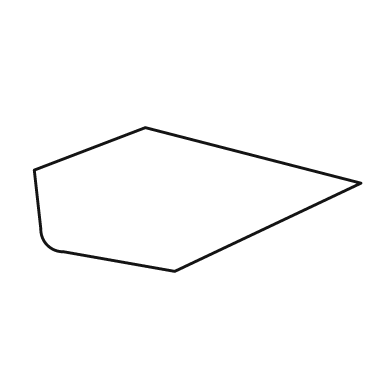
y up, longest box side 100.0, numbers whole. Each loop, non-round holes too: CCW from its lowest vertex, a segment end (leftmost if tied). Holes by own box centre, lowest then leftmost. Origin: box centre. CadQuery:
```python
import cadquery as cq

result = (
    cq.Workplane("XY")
    .moveTo(-7.0, -22.0)
    .lineTo(50.0, 5.0)
    .lineTo(-16.0, 22.0)
    .lineTo(-50.0, 9.0)
    .lineTo(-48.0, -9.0)
    .threePointArc((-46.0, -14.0), (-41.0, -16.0))
    .close()
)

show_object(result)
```